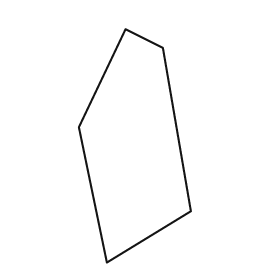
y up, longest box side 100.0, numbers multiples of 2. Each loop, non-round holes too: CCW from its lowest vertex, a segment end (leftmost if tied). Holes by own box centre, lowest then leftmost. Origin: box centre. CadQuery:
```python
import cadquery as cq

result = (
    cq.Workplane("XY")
    .moveTo(-12.0, -50.0)
    .lineTo(24.0, -28.0)
    .lineTo(12.0, 42.0)
    .lineTo(-4.0, 50.0)
    .lineTo(-24.0, 8.0)
    .close()
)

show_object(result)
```